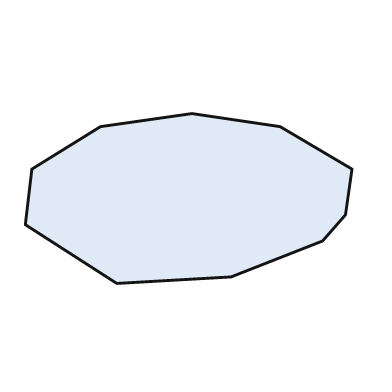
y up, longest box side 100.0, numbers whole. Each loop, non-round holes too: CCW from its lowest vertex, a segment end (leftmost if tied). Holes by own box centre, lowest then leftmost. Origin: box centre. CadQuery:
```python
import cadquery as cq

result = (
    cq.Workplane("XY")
    .moveTo(-22.0, -26.0)
    .lineTo(13.0, -24.0)
    .lineTo(41.0, -13.0)
    .lineTo(48.0, -5.0)
    .lineTo(50.0, 9.0)
    .lineTo(28.0, 22.0)
    .lineTo(1.0, 26.0)
    .lineTo(-27.0, 22.0)
    .lineTo(-48.0, 9.0)
    .lineTo(-50.0, -8.0)
    .close()
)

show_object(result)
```